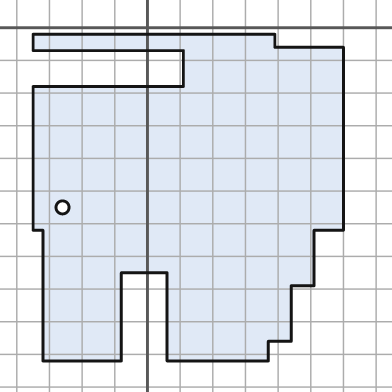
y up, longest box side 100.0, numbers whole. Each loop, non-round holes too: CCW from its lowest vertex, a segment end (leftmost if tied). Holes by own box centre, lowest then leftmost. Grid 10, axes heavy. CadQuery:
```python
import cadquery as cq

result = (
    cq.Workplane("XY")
    .moveTo(-32.0, -102.0)
    .lineTo(-8.0, -102.0)
    .lineTo(-8.0, -75.0)
    .lineTo(6.0, -75.0)
    .lineTo(6.0, -102.0)
    .lineTo(37.0, -102.0)
    .lineTo(37.0, -96.0)
    .lineTo(44.0, -96.0)
    .lineTo(44.0, -79.0)
    .lineTo(51.0, -79.0)
    .lineTo(51.0, -62.0)
    .lineTo(60.0, -62.0)
    .lineTo(60.0, -6.0)
    .lineTo(39.0, -6.0)
    .lineTo(39.0, -2.0)
    .lineTo(-35.0, -2.0)
    .lineTo(-35.0, -7.0)
    .lineTo(11.0, -7.0)
    .lineTo(11.0, -18.0)
    .lineTo(-35.0, -18.0)
    .lineTo(-35.0, -62.0)
    .lineTo(-32.0, -62.0)
    .close()
    .moveTo(-26.0, -55.0)
    .circle(2.0)
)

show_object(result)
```